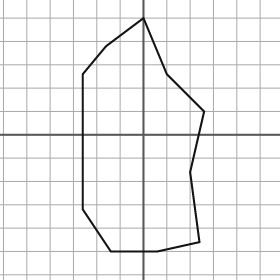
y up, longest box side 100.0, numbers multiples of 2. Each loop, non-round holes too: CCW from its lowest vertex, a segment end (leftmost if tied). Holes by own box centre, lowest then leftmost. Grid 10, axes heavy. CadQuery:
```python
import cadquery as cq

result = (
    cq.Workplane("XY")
    .moveTo(-14.0, -50.0)
    .lineTo(6.0, -50.0)
    .lineTo(24.0, -46.0)
    .lineTo(20.0, -16.0)
    .lineTo(26.0, 10.0)
    .lineTo(10.0, 26.0)
    .lineTo(0.0, 50.0)
    .lineTo(-16.0, 38.0)
    .lineTo(-26.0, 26.0)
    .lineTo(-26.0, -32.0)
    .close()
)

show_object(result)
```